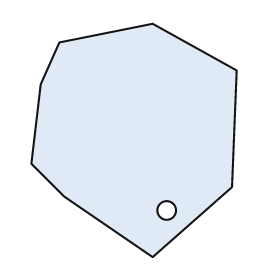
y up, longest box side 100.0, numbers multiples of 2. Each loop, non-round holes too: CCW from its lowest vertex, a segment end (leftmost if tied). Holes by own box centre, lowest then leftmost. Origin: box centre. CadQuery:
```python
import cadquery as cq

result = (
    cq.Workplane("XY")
    .moveTo(8.0, -50.0)
    .lineTo(42.0, -20.0)
    .lineTo(44.0, 30.0)
    .lineTo(8.0, 50.0)
    .lineTo(-32.0, 42.0)
    .lineTo(-40.0, 24.0)
    .lineTo(-44.0, -10.0)
    .lineTo(-30.0, -24.0)
    .close()
    .moveTo(14.0, -30.0)
    .circle(4.0)
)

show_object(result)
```